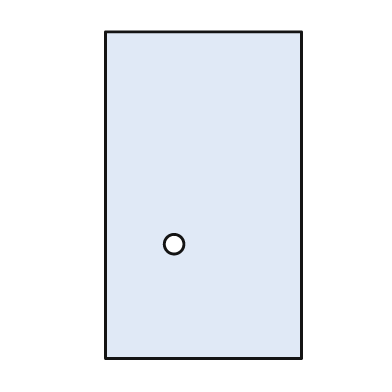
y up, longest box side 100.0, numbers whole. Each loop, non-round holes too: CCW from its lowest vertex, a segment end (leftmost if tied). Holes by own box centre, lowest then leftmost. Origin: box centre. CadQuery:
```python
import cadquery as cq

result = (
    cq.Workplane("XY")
    .moveTo(-30.0, -50.0)
    .lineTo(30.0, -50.0)
    .lineTo(30.0, 50.0)
    .lineTo(-30.0, 50.0)
    .close()
    .moveTo(-9.0, -15.0)
    .circle(3.0)
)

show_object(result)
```